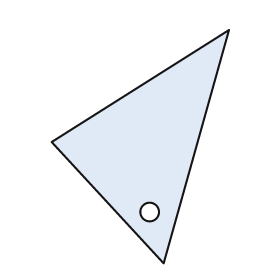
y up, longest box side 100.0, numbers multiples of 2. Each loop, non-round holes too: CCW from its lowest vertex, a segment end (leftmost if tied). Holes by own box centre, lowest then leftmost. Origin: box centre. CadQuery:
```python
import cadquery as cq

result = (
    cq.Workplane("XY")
    .moveTo(10.0, -50.0)
    .lineTo(38.0, 50.0)
    .lineTo(-38.0, 2.0)
    .close()
    .moveTo(4.0, -28.0)
    .circle(4.0)
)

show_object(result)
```